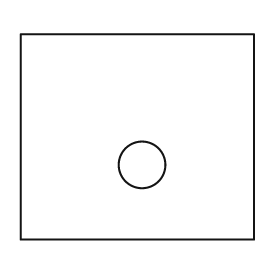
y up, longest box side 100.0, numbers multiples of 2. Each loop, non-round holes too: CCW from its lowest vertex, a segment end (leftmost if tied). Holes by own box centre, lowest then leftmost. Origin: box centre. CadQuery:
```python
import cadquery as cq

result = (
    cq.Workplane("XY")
    .moveTo(-50.0, -44.0)
    .lineTo(50.0, -44.0)
    .lineTo(50.0, 44.0)
    .lineTo(-50.0, 44.0)
    .close()
    .moveTo(2.0, -12.0)
    .circle(10.0)
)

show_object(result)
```